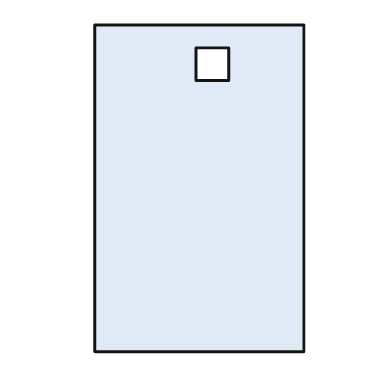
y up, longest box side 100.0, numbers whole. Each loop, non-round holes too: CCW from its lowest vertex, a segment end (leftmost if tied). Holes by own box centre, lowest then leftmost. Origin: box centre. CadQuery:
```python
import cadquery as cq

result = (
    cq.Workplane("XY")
    .moveTo(-32.0, -50.0)
    .lineTo(32.0, -50.0)
    .lineTo(32.0, 50.0)
    .lineTo(-32.0, 50.0)
    .close()
    .moveTo(-1.0, 33.0)
    .lineTo(9.0, 33.0)
    .lineTo(9.0, 43.0)
    .lineTo(-1.0, 43.0)
    .close()
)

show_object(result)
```